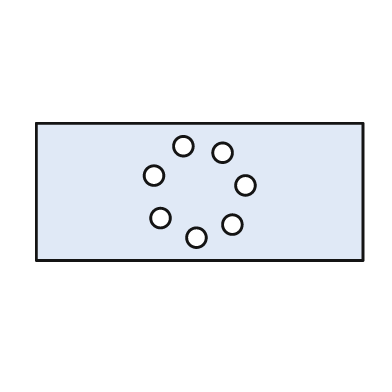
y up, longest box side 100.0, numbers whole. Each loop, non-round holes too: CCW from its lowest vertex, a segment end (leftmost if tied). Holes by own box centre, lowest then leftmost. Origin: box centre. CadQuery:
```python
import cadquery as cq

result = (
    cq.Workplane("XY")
    .moveTo(-50.0, -21.0)
    .lineTo(50.0, -21.0)
    .lineTo(50.0, 21.0)
    .lineTo(-50.0, 21.0)
    .close()
    .moveTo(-1.0, -14.0)
    .circle(3.0)
    .moveTo(10.0, -10.0)
    .circle(3.0)
    .moveTo(-12.0, -8.0)
    .circle(3.0)
    .moveTo(14.0, 2.0)
    .circle(3.0)
    .moveTo(-14.0, 5.0)
    .circle(3.0)
    .moveTo(7.0, 12.0)
    .circle(3.0)
    .moveTo(-5.0, 14.0)
    .circle(3.0)
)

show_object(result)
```